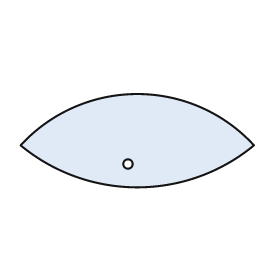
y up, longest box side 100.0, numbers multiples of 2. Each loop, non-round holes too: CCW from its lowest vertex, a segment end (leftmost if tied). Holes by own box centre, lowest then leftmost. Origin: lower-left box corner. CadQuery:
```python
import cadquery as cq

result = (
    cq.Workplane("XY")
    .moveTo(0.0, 18.0)
    .threePointArc((50.0, 0.0), (100.0, 18.0))
    .threePointArc((50.0, 40.0), (0.0, 18.0))
    .close()
    .moveTo(46.0, 10.0)
    .circle(2.0)
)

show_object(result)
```